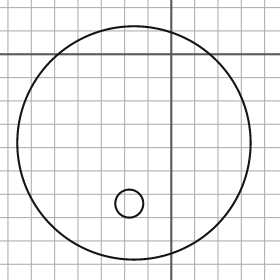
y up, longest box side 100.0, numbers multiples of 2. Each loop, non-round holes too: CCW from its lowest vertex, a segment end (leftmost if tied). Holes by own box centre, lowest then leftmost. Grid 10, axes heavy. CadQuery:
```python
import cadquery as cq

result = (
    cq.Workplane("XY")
    .moveTo(-16.0, -38.0)
    .circle(50.0)
    .moveTo(-18.0, -64.0)
    .circle(6.0)
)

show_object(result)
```